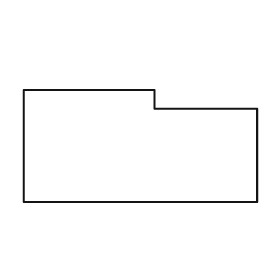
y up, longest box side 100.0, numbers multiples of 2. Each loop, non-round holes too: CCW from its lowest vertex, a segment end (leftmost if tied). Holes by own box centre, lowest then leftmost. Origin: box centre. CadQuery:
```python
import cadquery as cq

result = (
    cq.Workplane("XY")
    .moveTo(-50.0, -24.0)
    .lineTo(50.0, -24.0)
    .lineTo(50.0, 16.0)
    .lineTo(6.0, 16.0)
    .lineTo(6.0, 24.0)
    .lineTo(-50.0, 24.0)
    .close()
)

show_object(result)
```